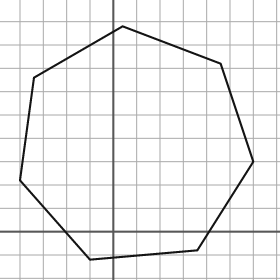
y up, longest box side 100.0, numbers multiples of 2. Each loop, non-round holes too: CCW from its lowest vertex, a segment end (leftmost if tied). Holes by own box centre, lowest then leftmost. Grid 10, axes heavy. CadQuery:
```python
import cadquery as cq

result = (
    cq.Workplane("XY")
    .moveTo(-10.0, -12.0)
    .lineTo(36.0, -8.0)
    .lineTo(60.0, 30.0)
    .lineTo(46.0, 72.0)
    .lineTo(4.0, 88.0)
    .lineTo(-34.0, 66.0)
    .lineTo(-40.0, 22.0)
    .close()
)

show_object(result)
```